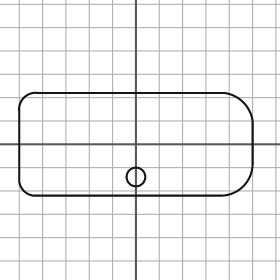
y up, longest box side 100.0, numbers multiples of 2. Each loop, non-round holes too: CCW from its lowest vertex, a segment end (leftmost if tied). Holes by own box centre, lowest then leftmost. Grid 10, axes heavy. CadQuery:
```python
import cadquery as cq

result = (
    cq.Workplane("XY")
    .moveTo(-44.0, -22.0)
    .lineTo(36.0, -22.0)
    .threePointArc((46.0, -18.0), (50.0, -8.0))
    .lineTo(50.0, 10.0)
    .threePointArc((46.0, 18.0), (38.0, 22.0))
    .lineTo(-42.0, 22.0)
    .threePointArc((-48.0, 20.0), (-50.0, 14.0))
    .lineTo(-50.0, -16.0)
    .threePointArc((-48.0, -20.0), (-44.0, -22.0))
    .close()
    .moveTo(0.0, -14.0)
    .circle(4.0)
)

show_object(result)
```